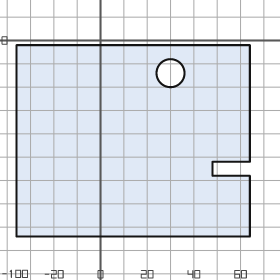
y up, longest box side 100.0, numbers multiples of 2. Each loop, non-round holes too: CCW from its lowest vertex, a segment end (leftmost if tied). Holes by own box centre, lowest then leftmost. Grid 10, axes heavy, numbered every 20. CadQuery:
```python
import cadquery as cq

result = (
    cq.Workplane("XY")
    .moveTo(-36.0, -84.0)
    .lineTo(64.0, -84.0)
    .lineTo(64.0, -58.0)
    .lineTo(48.0, -58.0)
    .lineTo(48.0, -52.0)
    .lineTo(64.0, -52.0)
    .lineTo(64.0, -2.0)
    .lineTo(-36.0, -2.0)
    .close()
    .moveTo(30.0, -14.0)
    .circle(6.0)
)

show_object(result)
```